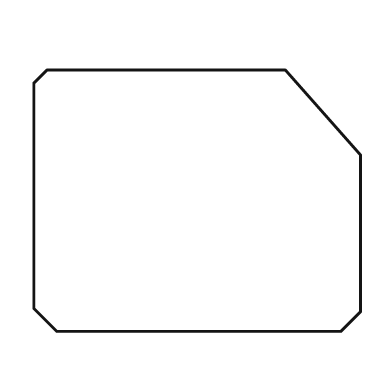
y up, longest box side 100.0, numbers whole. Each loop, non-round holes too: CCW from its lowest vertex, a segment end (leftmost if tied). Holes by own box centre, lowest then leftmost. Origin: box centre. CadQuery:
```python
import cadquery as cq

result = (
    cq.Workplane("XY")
    .moveTo(-43.0, -40.0)
    .lineTo(44.0, -40.0)
    .lineTo(50.0, -34.0)
    .lineTo(50.0, 14.0)
    .lineTo(27.0, 40.0)
    .lineTo(-46.0, 40.0)
    .lineTo(-50.0, 36.0)
    .lineTo(-50.0, -33.0)
    .close()
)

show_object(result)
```